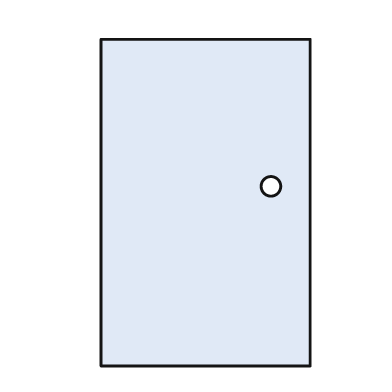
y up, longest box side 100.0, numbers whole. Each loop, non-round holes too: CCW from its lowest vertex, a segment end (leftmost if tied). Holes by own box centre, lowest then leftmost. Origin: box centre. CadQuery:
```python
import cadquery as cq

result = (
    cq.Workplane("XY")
    .moveTo(-32.0, -50.0)
    .lineTo(32.0, -50.0)
    .lineTo(32.0, 50.0)
    .lineTo(-32.0, 50.0)
    .close()
    .moveTo(20.0, 5.0)
    .circle(3.0)
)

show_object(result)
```